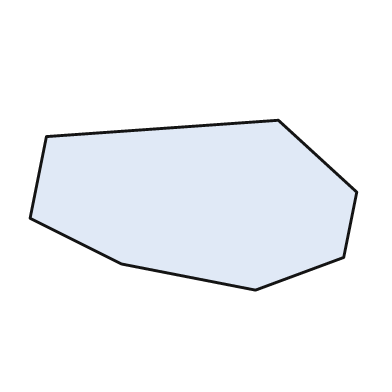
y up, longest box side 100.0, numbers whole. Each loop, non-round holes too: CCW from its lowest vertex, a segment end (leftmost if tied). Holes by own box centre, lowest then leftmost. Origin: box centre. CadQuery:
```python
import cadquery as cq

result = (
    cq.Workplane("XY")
    .moveTo(19.0, -26.0)
    .lineTo(46.0, -16.0)
    .lineTo(50.0, 4.0)
    .lineTo(26.0, 26.0)
    .lineTo(-45.0, 21.0)
    .lineTo(-50.0, -4.0)
    .lineTo(-22.0, -18.0)
    .close()
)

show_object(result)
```